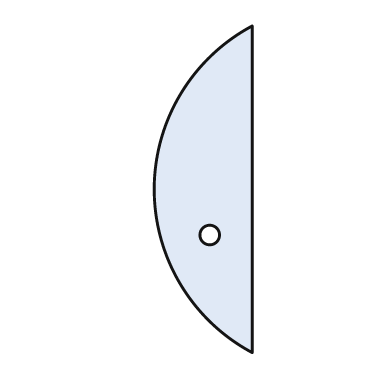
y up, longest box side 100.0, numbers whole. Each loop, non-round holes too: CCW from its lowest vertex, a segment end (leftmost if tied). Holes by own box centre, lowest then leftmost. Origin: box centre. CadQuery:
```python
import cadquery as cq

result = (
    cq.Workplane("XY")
    .moveTo(15.0, -50.0)
    .lineTo(15.0, 50.0)
    .threePointArc((-15.0, 0.0), (15.0, -50.0))
    .close()
    .moveTo(2.0, -14.0)
    .circle(3.0)
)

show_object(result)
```